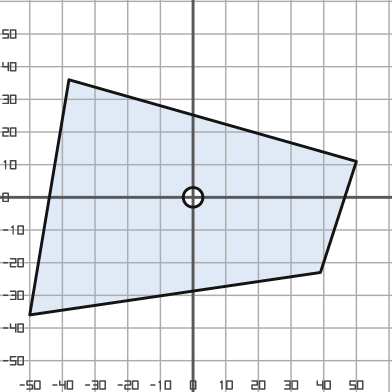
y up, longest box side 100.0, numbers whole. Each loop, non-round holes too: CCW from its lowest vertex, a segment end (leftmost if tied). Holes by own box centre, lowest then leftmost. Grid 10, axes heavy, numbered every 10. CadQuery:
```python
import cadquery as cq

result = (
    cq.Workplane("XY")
    .moveTo(-50.0, -36.0)
    .lineTo(39.0, -23.0)
    .lineTo(50.0, 11.0)
    .lineTo(-38.0, 36.0)
    .close()
    .moveTo(0.0, 0.0)
    .circle(3.0)
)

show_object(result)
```